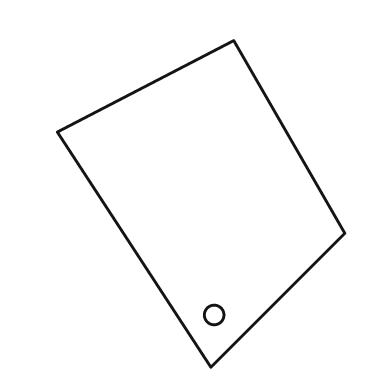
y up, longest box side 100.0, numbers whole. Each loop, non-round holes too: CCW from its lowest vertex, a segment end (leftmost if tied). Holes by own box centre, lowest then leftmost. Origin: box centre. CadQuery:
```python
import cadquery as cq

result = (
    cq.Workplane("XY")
    .moveTo(3.0, -50.0)
    .lineTo(44.0, -9.0)
    .lineTo(10.0, 50.0)
    .lineTo(-44.0, 22.0)
    .close()
    .moveTo(4.0, -34.0)
    .circle(3.0)
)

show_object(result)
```